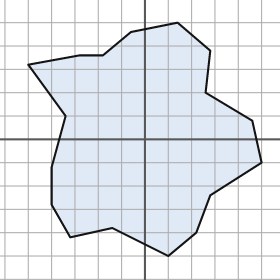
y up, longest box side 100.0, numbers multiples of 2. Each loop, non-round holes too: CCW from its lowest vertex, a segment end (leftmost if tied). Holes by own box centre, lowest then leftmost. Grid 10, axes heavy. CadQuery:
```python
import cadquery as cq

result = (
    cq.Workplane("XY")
    .moveTo(10.0, -50.0)
    .lineTo(22.0, -40.0)
    .lineTo(28.0, -24.0)
    .lineTo(50.0, -10.0)
    .lineTo(46.0, 8.0)
    .lineTo(26.0, 20.0)
    .lineTo(28.0, 38.0)
    .lineTo(14.0, 50.0)
    .lineTo(-6.0, 46.0)
    .lineTo(-18.0, 36.0)
    .lineTo(-28.0, 36.0)
    .lineTo(-50.0, 32.0)
    .lineTo(-34.0, 10.0)
    .lineTo(-40.0, -12.0)
    .lineTo(-40.0, -28.0)
    .lineTo(-32.0, -42.0)
    .lineTo(-14.0, -38.0)
    .close()
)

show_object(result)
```